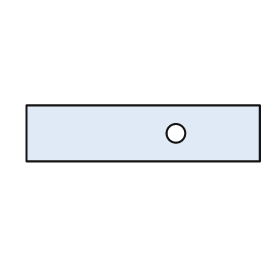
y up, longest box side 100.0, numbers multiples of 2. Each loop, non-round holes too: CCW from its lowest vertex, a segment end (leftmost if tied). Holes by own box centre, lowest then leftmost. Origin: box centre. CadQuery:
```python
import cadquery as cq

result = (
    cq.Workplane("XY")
    .moveTo(-50.0, -12.0)
    .lineTo(50.0, -12.0)
    .lineTo(50.0, 12.0)
    .lineTo(-50.0, 12.0)
    .close()
    .moveTo(14.0, 0.0)
    .circle(4.0)
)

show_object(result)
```